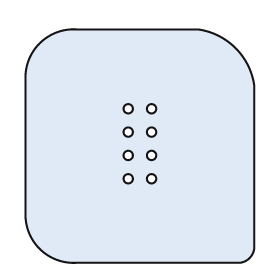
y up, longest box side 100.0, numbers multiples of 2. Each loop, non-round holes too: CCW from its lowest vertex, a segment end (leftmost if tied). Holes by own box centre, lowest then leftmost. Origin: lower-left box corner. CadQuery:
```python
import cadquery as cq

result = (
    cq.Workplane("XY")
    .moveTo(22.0, 0.0)
    .lineTo(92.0, 0.0)
    .threePointArc((96.0, 2.0), (98.0, 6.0))
    .lineTo(98.0, 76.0)
    .threePointArc((90.0, 92.0), (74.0, 100.0))
    .lineTo(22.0, 100.0)
    .threePointArc((6.0, 94.0), (0.0, 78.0))
    .lineTo(0.0, 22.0)
    .threePointArc((6.0, 6.0), (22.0, 0.0))
    .close()
    .moveTo(44.0, 36.0)
    .circle(2.0)
    .moveTo(54.0, 36.0)
    .circle(2.0)
    .moveTo(44.0, 46.0)
    .circle(2.0)
    .moveTo(54.0, 46.0)
    .circle(2.0)
    .moveTo(44.0, 56.0)
    .circle(2.0)
    .moveTo(54.0, 56.0)
    .circle(2.0)
    .moveTo(44.0, 66.0)
    .circle(2.0)
    .moveTo(54.0, 66.0)
    .circle(2.0)
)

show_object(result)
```